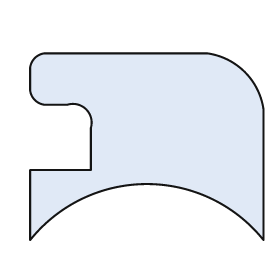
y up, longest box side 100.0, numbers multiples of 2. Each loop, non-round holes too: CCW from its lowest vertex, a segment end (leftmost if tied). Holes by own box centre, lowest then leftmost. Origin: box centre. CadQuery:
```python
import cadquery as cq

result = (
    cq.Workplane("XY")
    .moveTo(-50.0, -40.0)
    .threePointArc((0.0, -16.0), (50.0, -40.0))
    .lineTo(50.0, 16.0)
    .threePointArc((42.0, 32.0), (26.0, 40.0))
    .lineTo(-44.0, 40.0)
    .threePointArc((-48.0, 38.0), (-50.0, 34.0))
    .lineTo(-50.0, 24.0)
    .threePointArc((-48.0, 20.0), (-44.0, 18.0))
    .lineTo(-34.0, 18.0)
    .threePointArc((-26.0, 16.0), (-24.0, 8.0))
    .lineTo(-24.0, -10.0)
    .lineTo(-50.0, -10.0)
    .close()
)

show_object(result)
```